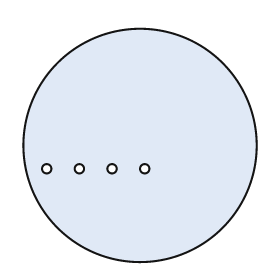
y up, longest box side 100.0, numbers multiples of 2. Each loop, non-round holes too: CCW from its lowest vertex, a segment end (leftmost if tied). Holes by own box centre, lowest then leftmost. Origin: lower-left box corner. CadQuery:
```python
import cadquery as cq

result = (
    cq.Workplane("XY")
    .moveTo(50.0, 50.0)
    .circle(50.0)
    .moveTo(10.0, 40.0)
    .circle(2.0)
    .moveTo(24.0, 40.0)
    .circle(2.0)
    .moveTo(38.0, 40.0)
    .circle(2.0)
    .moveTo(52.0, 40.0)
    .circle(2.0)
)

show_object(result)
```